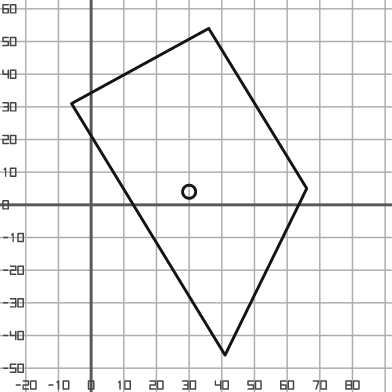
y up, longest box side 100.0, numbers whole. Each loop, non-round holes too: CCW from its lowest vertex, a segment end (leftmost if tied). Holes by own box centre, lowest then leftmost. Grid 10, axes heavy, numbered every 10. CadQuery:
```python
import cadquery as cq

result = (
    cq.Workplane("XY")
    .moveTo(41.0, -46.0)
    .lineTo(66.0, 5.0)
    .lineTo(36.0, 54.0)
    .lineTo(-6.0, 31.0)
    .close()
    .moveTo(30.0, 4.0)
    .circle(2.0)
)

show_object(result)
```